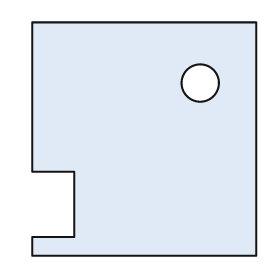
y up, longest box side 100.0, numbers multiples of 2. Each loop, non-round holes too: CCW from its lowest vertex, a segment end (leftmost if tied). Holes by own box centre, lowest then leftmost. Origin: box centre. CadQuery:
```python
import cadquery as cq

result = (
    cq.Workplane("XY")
    .moveTo(-48.0, -50.0)
    .lineTo(48.0, -50.0)
    .lineTo(48.0, 50.0)
    .lineTo(-48.0, 50.0)
    .lineTo(-48.0, -14.0)
    .lineTo(-30.0, -14.0)
    .lineTo(-30.0, -42.0)
    .lineTo(-48.0, -42.0)
    .close()
    .moveTo(24.0, 24.0)
    .circle(8.0)
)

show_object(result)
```